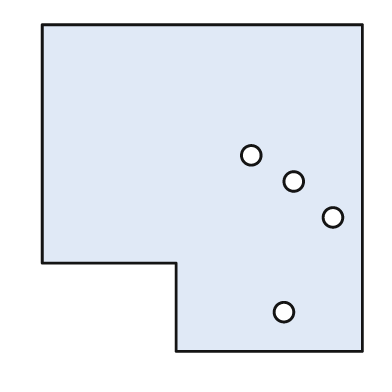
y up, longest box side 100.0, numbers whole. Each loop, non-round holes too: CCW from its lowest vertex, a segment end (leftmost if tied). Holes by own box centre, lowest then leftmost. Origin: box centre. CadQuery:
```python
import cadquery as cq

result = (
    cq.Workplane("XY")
    .moveTo(-8.0, -50.0)
    .lineTo(49.0, -50.0)
    .lineTo(49.0, 50.0)
    .lineTo(-49.0, 50.0)
    .lineTo(-49.0, -23.0)
    .lineTo(-8.0, -23.0)
    .close()
    .moveTo(25.0, -38.0)
    .circle(3.0)
    .moveTo(40.0, -9.0)
    .circle(3.0)
    .moveTo(28.0, 2.0)
    .circle(3.0)
    .moveTo(15.0, 10.0)
    .circle(3.0)
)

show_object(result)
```